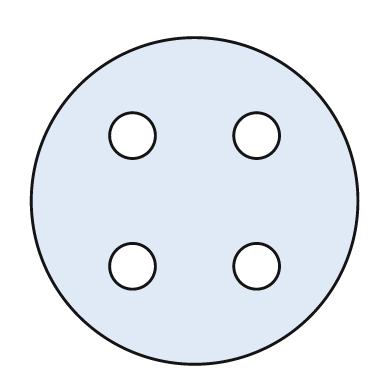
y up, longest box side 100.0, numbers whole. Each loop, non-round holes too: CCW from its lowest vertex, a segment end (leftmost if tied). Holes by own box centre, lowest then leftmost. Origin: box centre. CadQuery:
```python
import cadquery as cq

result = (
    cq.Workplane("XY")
    .moveTo(0.0, 0.0)
    .circle(50.0)
    .moveTo(-19.0, -20.0)
    .circle(7.0)
    .moveTo(19.0, -20.0)
    .circle(7.0)
    .moveTo(-19.0, 20.0)
    .circle(7.0)
    .moveTo(19.0, 20.0)
    .circle(7.0)
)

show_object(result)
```